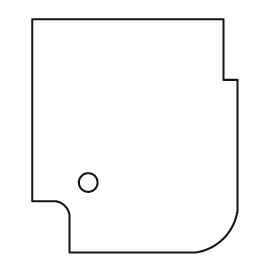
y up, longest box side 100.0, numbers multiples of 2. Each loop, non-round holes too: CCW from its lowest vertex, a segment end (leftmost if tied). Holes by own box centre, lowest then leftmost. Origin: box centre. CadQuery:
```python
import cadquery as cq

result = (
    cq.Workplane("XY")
    .moveTo(-28.0, -50.0)
    .lineTo(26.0, -50.0)
    .threePointArc((38.0, -44.0), (44.0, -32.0))
    .lineTo(44.0, 24.0)
    .lineTo(38.0, 24.0)
    .lineTo(38.0, 50.0)
    .lineTo(-44.0, 50.0)
    .lineTo(-44.0, -28.0)
    .lineTo(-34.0, -28.0)
    .threePointArc((-30.0, -30.0), (-28.0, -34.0))
    .close()
    .moveTo(-20.0, -20.0)
    .circle(4.0)
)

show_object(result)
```